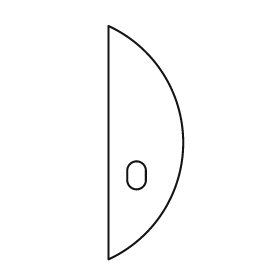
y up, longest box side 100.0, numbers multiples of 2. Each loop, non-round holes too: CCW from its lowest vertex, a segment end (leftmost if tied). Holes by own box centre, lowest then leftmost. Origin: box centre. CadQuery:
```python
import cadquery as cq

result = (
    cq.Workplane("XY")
    .moveTo(-16.0, -50.0)
    .threePointArc((16.0, 0.0), (-16.0, 50.0))
    .close()
    .moveTo(-8.0, -16.0)
    .threePointArc((-4.0, -20.0), (0.0, -16.0))
    .lineTo(0.0, -12.0)
    .threePointArc((-4.0, -8.0), (-8.0, -12.0))
    .close()
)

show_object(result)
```